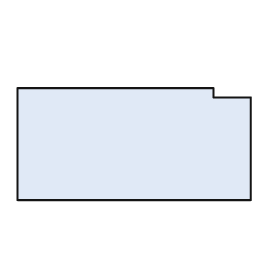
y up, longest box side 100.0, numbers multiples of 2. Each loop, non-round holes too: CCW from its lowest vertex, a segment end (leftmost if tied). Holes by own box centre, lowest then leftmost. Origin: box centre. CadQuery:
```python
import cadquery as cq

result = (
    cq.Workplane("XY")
    .moveTo(-50.0, -24.0)
    .lineTo(50.0, -24.0)
    .lineTo(50.0, 20.0)
    .lineTo(34.0, 20.0)
    .lineTo(34.0, 24.0)
    .lineTo(-50.0, 24.0)
    .close()
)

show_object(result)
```